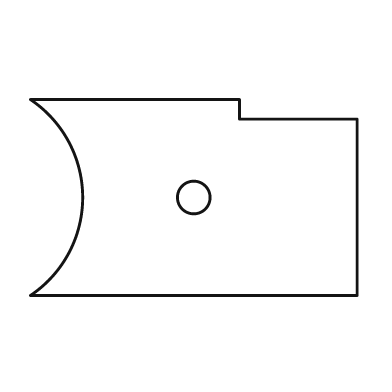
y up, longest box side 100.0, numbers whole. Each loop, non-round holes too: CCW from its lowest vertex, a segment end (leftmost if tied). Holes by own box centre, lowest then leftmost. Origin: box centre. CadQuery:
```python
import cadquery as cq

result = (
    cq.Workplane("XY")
    .moveTo(-50.0, -30.0)
    .lineTo(50.0, -30.0)
    .lineTo(50.0, 24.0)
    .lineTo(14.0, 24.0)
    .lineTo(14.0, 30.0)
    .lineTo(-50.0, 30.0)
    .threePointArc((-34.0, 0.0), (-50.0, -30.0))
    .close()
    .moveTo(0.0, 0.0)
    .circle(5.0)
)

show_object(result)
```